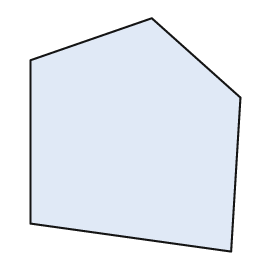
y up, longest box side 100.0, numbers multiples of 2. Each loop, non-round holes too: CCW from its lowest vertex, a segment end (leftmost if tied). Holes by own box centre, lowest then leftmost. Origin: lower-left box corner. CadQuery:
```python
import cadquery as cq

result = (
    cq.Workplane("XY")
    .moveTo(86.0, 0.0)
    .lineTo(90.0, 66.0)
    .lineTo(52.0, 100.0)
    .lineTo(0.0, 82.0)
    .lineTo(0.0, 12.0)
    .close()
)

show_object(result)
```